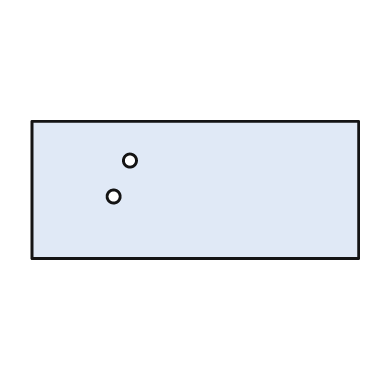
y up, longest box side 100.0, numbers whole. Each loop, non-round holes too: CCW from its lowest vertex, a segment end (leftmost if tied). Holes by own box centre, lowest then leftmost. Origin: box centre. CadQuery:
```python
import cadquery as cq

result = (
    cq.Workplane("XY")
    .moveTo(-50.0, -21.0)
    .lineTo(50.0, -21.0)
    .lineTo(50.0, 21.0)
    .lineTo(-50.0, 21.0)
    .close()
    .moveTo(-25.0, -2.0)
    .circle(2.0)
    .moveTo(-20.0, 9.0)
    .circle(2.0)
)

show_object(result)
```